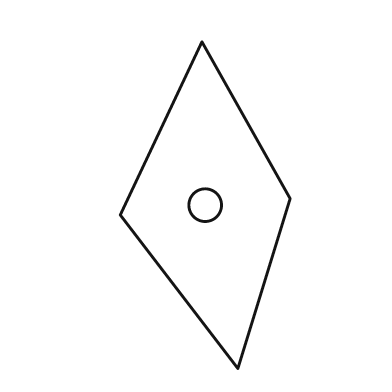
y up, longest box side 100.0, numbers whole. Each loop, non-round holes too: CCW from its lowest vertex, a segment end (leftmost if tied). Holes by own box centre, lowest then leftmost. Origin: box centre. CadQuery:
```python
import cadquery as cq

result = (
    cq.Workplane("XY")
    .moveTo(10.0, -50.0)
    .lineTo(26.0, 2.0)
    .lineTo(-1.0, 50.0)
    .lineTo(-26.0, -3.0)
    .close()
    .moveTo(0.0, 0.0)
    .circle(5.0)
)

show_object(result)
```